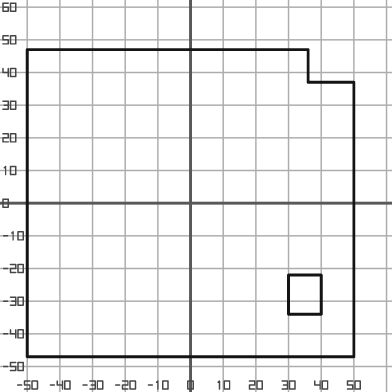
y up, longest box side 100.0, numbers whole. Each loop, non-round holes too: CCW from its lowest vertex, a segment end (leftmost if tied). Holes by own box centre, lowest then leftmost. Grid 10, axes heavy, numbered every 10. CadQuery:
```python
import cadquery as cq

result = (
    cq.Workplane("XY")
    .moveTo(-50.0, -47.0)
    .lineTo(50.0, -47.0)
    .lineTo(50.0, 37.0)
    .lineTo(36.0, 37.0)
    .lineTo(36.0, 47.0)
    .lineTo(-50.0, 47.0)
    .close()
    .moveTo(30.0, -34.0)
    .lineTo(40.0, -34.0)
    .lineTo(40.0, -22.0)
    .lineTo(30.0, -22.0)
    .close()
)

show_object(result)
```